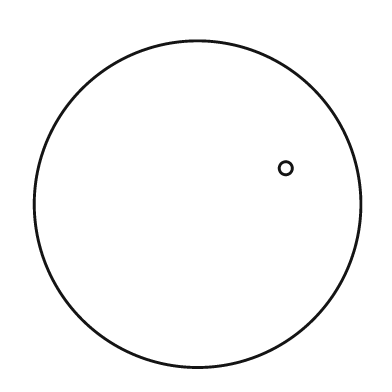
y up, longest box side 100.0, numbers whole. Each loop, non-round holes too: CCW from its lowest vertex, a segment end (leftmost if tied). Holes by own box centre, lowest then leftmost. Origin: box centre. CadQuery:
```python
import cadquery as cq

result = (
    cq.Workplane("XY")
    .moveTo(0.0, 0.0)
    .circle(50.0)
    .moveTo(27.0, 11.0)
    .circle(2.0)
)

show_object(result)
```